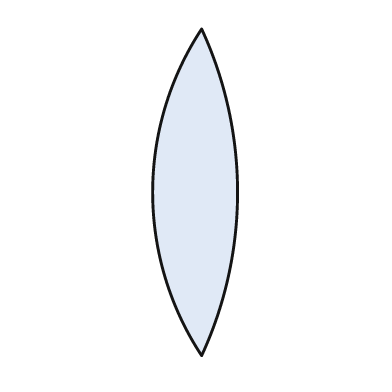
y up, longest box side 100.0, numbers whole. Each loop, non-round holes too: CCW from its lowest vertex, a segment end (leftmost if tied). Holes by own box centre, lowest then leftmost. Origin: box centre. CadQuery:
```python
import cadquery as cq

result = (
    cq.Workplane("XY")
    .moveTo(2.0, -50.0)
    .threePointArc((13.0, 0.0), (2.0, 50.0))
    .threePointArc((-13.0, 0.0), (2.0, -50.0))
    .close()
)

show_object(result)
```